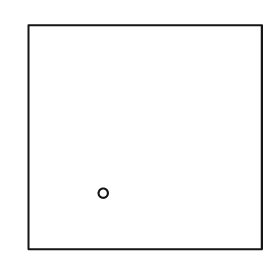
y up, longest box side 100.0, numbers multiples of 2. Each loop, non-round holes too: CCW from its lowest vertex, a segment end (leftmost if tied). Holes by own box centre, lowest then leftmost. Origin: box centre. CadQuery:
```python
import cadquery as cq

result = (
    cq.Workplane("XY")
    .moveTo(-50.0, -48.0)
    .lineTo(50.0, -48.0)
    .lineTo(50.0, 48.0)
    .lineTo(-50.0, 48.0)
    .close()
    .moveTo(-18.0, -24.0)
    .circle(2.0)
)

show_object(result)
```